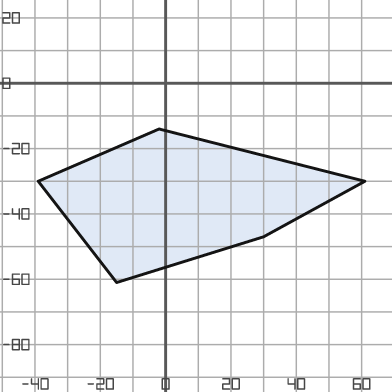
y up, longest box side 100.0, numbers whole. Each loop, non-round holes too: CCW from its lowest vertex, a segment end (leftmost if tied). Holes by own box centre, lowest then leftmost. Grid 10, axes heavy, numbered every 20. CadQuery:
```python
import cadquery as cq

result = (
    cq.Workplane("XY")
    .moveTo(-15.0, -61.0)
    .lineTo(30.0, -47.0)
    .lineTo(61.0, -30.0)
    .lineTo(-2.0, -14.0)
    .lineTo(-39.0, -30.0)
    .close()
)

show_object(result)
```